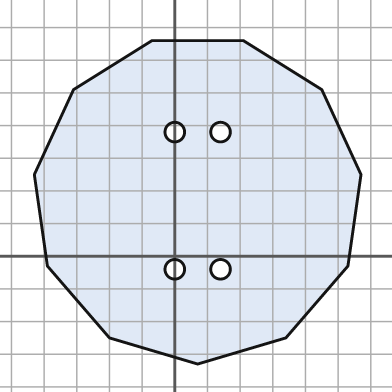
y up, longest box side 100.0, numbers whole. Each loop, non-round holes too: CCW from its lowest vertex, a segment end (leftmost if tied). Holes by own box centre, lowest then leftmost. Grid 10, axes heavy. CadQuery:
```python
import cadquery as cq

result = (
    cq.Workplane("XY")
    .moveTo(7.0, -33.0)
    .lineTo(34.0, -25.0)
    .lineTo(53.0, -3.0)
    .lineTo(57.0, 25.0)
    .lineTo(45.0, 51.0)
    .lineTo(21.0, 66.0)
    .lineTo(-7.0, 66.0)
    .lineTo(-31.0, 51.0)
    .lineTo(-43.0, 25.0)
    .lineTo(-39.0, -3.0)
    .lineTo(-20.0, -25.0)
    .close()
    .moveTo(0.0, -4.0)
    .circle(3.0)
    .moveTo(14.0, -4.0)
    .circle(3.0)
    .moveTo(0.0, 38.0)
    .circle(3.0)
    .moveTo(14.0, 38.0)
    .circle(3.0)
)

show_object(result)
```